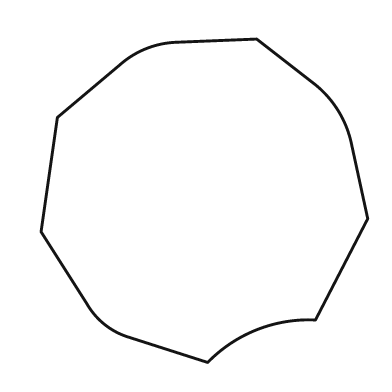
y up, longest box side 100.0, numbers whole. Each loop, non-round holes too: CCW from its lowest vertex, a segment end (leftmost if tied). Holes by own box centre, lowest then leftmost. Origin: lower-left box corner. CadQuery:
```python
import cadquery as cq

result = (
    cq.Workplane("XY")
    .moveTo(51.0, 0.0)
    .threePointArc((66.0, 10.0), (84.0, 13.0))
    .lineTo(100.0, 44.0)
    .lineTo(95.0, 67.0)
    .threePointArc((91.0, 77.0), (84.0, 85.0))
    .lineTo(66.0, 99.0)
    .lineTo(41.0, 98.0)
    .threePointArc((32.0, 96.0), (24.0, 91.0))
    .lineTo(5.0, 75.0)
    .lineTo(0.0, 40.0)
    .lineTo(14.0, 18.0)
    .threePointArc((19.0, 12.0), (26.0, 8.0))
    .close()
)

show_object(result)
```